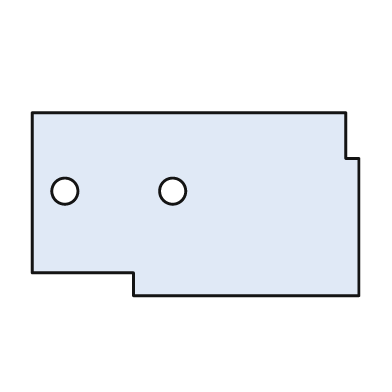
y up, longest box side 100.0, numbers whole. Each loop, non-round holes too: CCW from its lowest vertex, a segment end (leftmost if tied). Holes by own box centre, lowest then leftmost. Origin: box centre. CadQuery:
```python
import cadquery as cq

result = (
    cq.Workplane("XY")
    .moveTo(-19.0, -28.0)
    .lineTo(50.0, -28.0)
    .lineTo(50.0, 14.0)
    .lineTo(46.0, 14.0)
    .lineTo(46.0, 28.0)
    .lineTo(-50.0, 28.0)
    .lineTo(-50.0, -21.0)
    .lineTo(-19.0, -21.0)
    .close()
    .moveTo(-40.0, 4.0)
    .circle(4.0)
    .moveTo(-7.0, 4.0)
    .circle(4.0)
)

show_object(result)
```